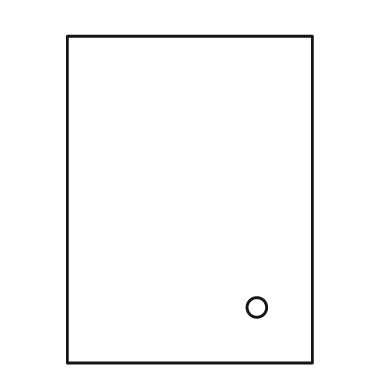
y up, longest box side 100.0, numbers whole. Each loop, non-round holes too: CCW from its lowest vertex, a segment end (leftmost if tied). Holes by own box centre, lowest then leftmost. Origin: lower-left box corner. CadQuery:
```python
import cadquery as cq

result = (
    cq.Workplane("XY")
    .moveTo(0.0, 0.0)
    .lineTo(75.0, 0.0)
    .lineTo(75.0, 100.0)
    .lineTo(0.0, 100.0)
    .close()
    .moveTo(58.0, 17.0)
    .circle(3.0)
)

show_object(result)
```